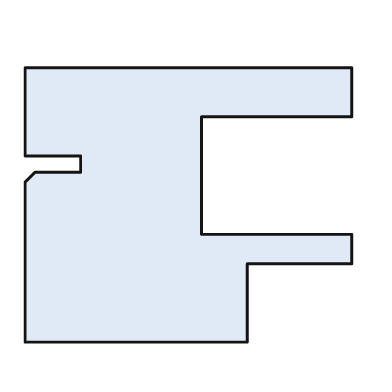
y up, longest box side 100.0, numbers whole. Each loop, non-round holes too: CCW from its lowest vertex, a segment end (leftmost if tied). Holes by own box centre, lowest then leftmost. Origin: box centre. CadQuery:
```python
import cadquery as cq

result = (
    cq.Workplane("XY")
    .moveTo(-50.0, -42.0)
    .lineTo(18.0, -42.0)
    .lineTo(18.0, -18.0)
    .lineTo(50.0, -18.0)
    .lineTo(50.0, -9.0)
    .lineTo(4.0, -9.0)
    .lineTo(4.0, 27.0)
    .lineTo(50.0, 27.0)
    .lineTo(50.0, 42.0)
    .lineTo(-50.0, 42.0)
    .lineTo(-50.0, 15.0)
    .lineTo(-33.0, 15.0)
    .lineTo(-33.0, 10.0)
    .lineTo(-47.0, 10.0)
    .lineTo(-50.0, 7.0)
    .close()
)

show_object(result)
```